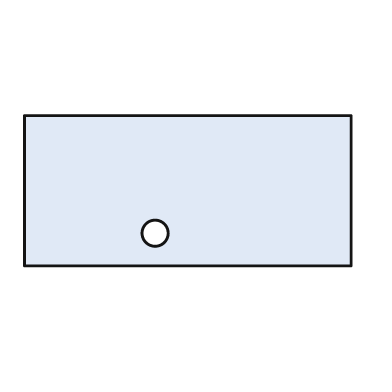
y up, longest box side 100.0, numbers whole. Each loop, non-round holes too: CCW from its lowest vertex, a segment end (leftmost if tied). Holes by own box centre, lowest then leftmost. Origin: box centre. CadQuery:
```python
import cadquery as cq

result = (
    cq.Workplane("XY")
    .moveTo(-50.0, -23.0)
    .lineTo(50.0, -23.0)
    .lineTo(50.0, 23.0)
    .lineTo(-50.0, 23.0)
    .close()
    .moveTo(-10.0, -13.0)
    .circle(4.0)
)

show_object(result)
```